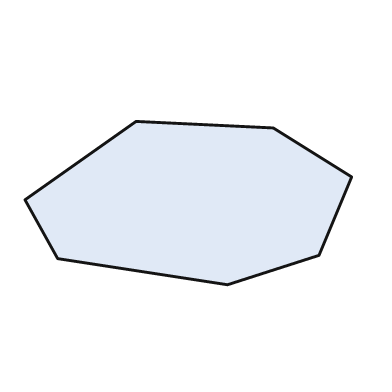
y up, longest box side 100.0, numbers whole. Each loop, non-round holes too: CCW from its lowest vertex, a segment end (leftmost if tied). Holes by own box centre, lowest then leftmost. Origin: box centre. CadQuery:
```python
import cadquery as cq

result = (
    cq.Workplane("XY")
    .moveTo(12.0, -25.0)
    .lineTo(40.0, -16.0)
    .lineTo(50.0, 8.0)
    .lineTo(26.0, 23.0)
    .lineTo(-16.0, 25.0)
    .lineTo(-50.0, 1.0)
    .lineTo(-40.0, -17.0)
    .close()
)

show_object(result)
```